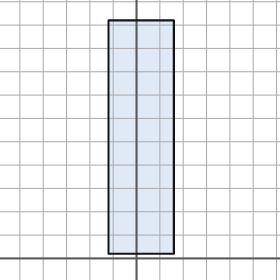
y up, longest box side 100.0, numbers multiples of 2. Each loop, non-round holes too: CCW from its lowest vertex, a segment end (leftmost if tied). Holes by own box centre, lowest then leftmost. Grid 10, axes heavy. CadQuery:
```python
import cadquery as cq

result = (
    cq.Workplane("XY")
    .moveTo(-12.0, 2.0)
    .lineTo(16.0, 2.0)
    .lineTo(16.0, 102.0)
    .lineTo(-12.0, 102.0)
    .close()
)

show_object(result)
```